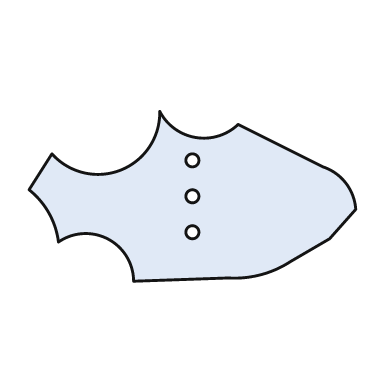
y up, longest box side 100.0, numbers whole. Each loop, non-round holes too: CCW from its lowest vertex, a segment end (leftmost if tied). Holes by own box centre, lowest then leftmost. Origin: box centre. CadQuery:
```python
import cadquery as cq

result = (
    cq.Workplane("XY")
    .moveTo(-18.0, -26.0)
    .lineTo(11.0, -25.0)
    .threePointArc((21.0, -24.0), (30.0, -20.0))
    .lineTo(42.0, -13.0)
    .lineTo(50.0, -4.0)
    .threePointArc((47.0, 4.0), (40.0, 9.0))
    .lineTo(14.0, 22.0)
    .threePointArc((1.0, 18.0), (-10.0, 26.0))
    .threePointArc((-22.0, 8.0), (-43.0, 13.0))
    .lineTo(-50.0, 2.0)
    .threePointArc((-44.0, -5.0), (-41.0, -14.0))
    .threePointArc((-26.0, -13.0), (-18.0, -26.0))
    .close()
    .moveTo(0.0, -11.0)
    .circle(2.0)
    .moveTo(0.0, 0.0)
    .circle(2.0)
    .moveTo(0.0, 11.0)
    .circle(2.0)
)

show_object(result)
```